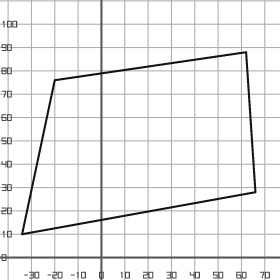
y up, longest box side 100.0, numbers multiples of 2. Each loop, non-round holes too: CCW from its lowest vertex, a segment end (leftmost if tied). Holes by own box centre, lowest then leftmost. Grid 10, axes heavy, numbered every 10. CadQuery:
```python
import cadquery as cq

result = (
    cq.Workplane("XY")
    .moveTo(-34.0, 10.0)
    .lineTo(66.0, 28.0)
    .lineTo(62.0, 88.0)
    .lineTo(-20.0, 76.0)
    .close()
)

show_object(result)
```